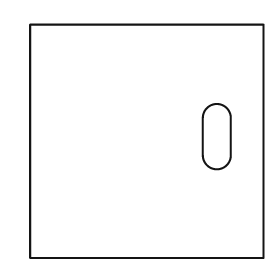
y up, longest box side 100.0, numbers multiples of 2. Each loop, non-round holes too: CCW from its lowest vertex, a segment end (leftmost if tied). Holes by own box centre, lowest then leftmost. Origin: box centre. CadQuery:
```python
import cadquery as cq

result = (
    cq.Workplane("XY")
    .moveTo(-50.0, -50.0)
    .lineTo(50.0, -50.0)
    .lineTo(50.0, 50.0)
    .lineTo(-50.0, 50.0)
    .close()
    .moveTo(24.0, -6.0)
    .threePointArc((30.0, -12.0), (36.0, -6.0))
    .lineTo(36.0, 10.0)
    .threePointArc((30.0, 16.0), (24.0, 10.0))
    .close()
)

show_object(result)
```